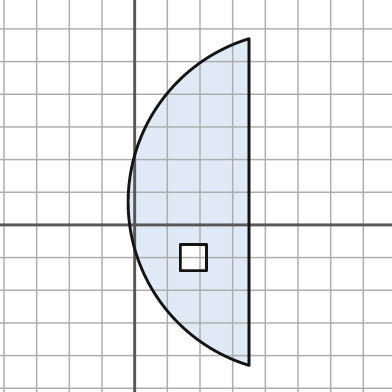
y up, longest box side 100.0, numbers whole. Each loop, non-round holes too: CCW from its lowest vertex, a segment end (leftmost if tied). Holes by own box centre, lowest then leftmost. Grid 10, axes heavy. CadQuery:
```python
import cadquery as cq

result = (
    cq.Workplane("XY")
    .moveTo(35.0, -43.0)
    .lineTo(35.0, 57.0)
    .threePointArc((-2.0, 7.0), (35.0, -43.0))
    .close()
    .moveTo(14.0, -14.0)
    .lineTo(22.0, -14.0)
    .lineTo(22.0, -6.0)
    .lineTo(14.0, -6.0)
    .close()
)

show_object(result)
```